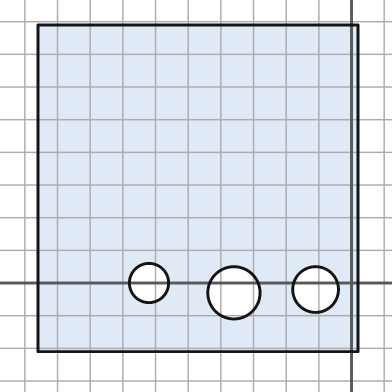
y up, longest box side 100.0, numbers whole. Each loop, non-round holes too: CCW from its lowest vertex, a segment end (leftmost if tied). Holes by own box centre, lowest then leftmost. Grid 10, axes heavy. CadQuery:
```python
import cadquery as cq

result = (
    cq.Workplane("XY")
    .moveTo(-96.0, -21.0)
    .lineTo(2.0, -21.0)
    .lineTo(2.0, 79.0)
    .lineTo(-96.0, 79.0)
    .close()
    .moveTo(-36.0, -3.0)
    .circle(8.0)
    .moveTo(-11.0, -2.0)
    .circle(7.0)
    .moveTo(-62.0, 0.0)
    .circle(6.0)
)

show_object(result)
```